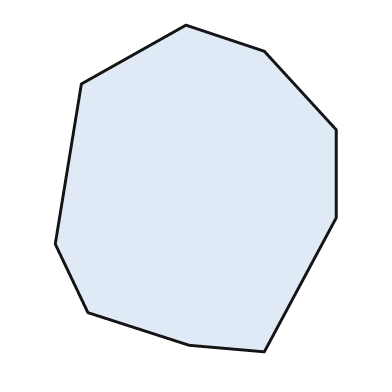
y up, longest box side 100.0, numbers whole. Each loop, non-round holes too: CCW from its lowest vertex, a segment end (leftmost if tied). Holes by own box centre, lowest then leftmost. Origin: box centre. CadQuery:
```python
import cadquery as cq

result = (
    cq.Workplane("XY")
    .moveTo(21.0, -50.0)
    .lineTo(43.0, -9.0)
    .lineTo(43.0, 18.0)
    .lineTo(21.0, 42.0)
    .lineTo(-3.0, 50.0)
    .lineTo(-35.0, 32.0)
    .lineTo(-43.0, -17.0)
    .lineTo(-33.0, -38.0)
    .lineTo(-2.0, -48.0)
    .close()
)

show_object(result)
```